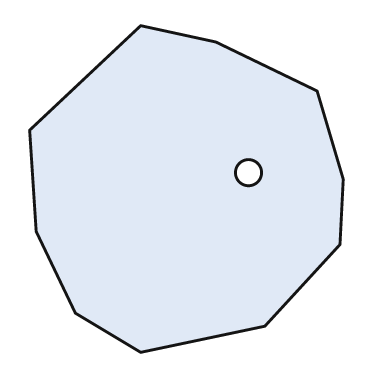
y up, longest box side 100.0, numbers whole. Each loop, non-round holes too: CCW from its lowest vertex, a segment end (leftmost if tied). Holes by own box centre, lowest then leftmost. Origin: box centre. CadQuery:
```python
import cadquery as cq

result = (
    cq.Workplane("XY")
    .moveTo(-14.0, -50.0)
    .lineTo(24.0, -42.0)
    .lineTo(47.0, -17.0)
    .lineTo(48.0, 3.0)
    .lineTo(40.0, 30.0)
    .lineTo(9.0, 45.0)
    .lineTo(-14.0, 50.0)
    .lineTo(-48.0, 18.0)
    .lineTo(-46.0, -13.0)
    .lineTo(-34.0, -38.0)
    .close()
    .moveTo(19.0, 5.0)
    .circle(4.0)
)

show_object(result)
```